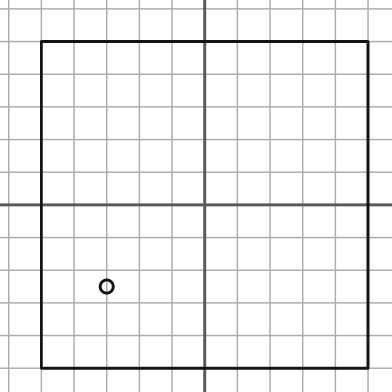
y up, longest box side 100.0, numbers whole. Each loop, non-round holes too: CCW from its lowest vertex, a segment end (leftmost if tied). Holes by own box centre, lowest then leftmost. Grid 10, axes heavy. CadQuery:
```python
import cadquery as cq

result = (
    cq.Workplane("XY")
    .moveTo(-50.0, -50.0)
    .lineTo(50.0, -50.0)
    .lineTo(50.0, 50.0)
    .lineTo(-50.0, 50.0)
    .close()
    .moveTo(-30.0, -25.0)
    .circle(2.0)
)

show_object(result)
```